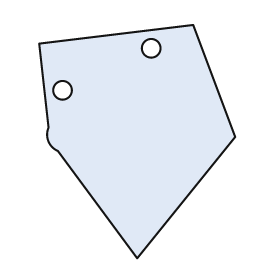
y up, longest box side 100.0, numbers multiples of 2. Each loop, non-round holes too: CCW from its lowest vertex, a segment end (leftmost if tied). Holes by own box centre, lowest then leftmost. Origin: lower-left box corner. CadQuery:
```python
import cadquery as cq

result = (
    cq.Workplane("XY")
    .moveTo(42.0, 0.0)
    .lineTo(84.0, 52.0)
    .lineTo(66.0, 100.0)
    .lineTo(0.0, 92.0)
    .lineTo(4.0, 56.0)
    .threePointArc((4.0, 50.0), (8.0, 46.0))
    .close()
    .moveTo(10.0, 72.0)
    .circle(4.0)
    .moveTo(48.0, 90.0)
    .circle(4.0)
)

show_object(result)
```